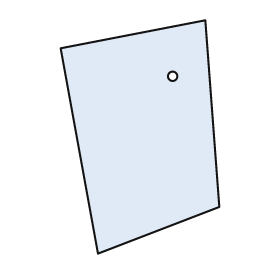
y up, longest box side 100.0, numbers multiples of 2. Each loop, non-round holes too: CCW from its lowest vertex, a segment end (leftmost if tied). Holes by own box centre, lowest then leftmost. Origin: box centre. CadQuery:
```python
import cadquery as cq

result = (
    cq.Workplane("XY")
    .moveTo(-18.0, -50.0)
    .lineTo(34.0, -30.0)
    .lineTo(28.0, 50.0)
    .lineTo(-34.0, 38.0)
    .close()
    .moveTo(14.0, 26.0)
    .circle(2.0)
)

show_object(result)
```